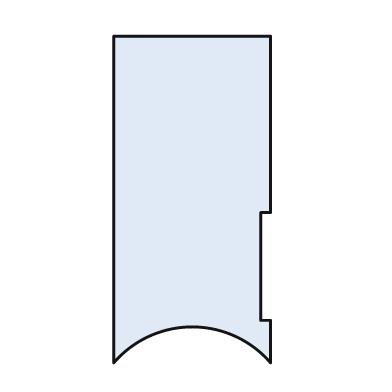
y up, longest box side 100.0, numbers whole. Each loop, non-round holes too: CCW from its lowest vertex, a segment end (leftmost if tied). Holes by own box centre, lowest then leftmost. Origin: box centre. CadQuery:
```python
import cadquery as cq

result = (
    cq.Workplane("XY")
    .moveTo(-24.0, -50.0)
    .threePointArc((0.0, -39.0), (24.0, -50.0))
    .lineTo(24.0, -37.0)
    .lineTo(21.0, -37.0)
    .lineTo(21.0, -4.0)
    .lineTo(24.0, -4.0)
    .lineTo(24.0, 50.0)
    .lineTo(-24.0, 50.0)
    .close()
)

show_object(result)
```